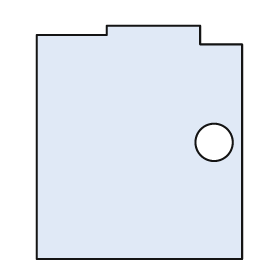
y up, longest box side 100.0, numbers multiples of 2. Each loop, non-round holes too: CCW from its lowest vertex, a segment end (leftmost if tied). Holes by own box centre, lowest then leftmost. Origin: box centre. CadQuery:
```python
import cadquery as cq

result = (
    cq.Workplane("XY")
    .moveTo(-44.0, -50.0)
    .lineTo(44.0, -50.0)
    .lineTo(44.0, 42.0)
    .lineTo(26.0, 42.0)
    .lineTo(26.0, 50.0)
    .lineTo(-14.0, 50.0)
    .lineTo(-14.0, 46.0)
    .lineTo(-44.0, 46.0)
    .close()
    .moveTo(32.0, 0.0)
    .circle(8.0)
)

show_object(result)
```